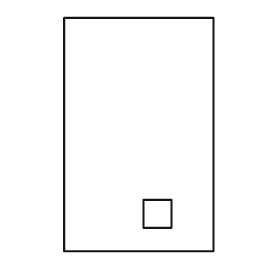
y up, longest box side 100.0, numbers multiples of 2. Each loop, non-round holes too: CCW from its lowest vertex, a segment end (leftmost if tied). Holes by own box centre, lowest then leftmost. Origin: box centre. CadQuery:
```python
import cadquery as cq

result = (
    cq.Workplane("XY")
    .moveTo(-32.0, -50.0)
    .lineTo(32.0, -50.0)
    .lineTo(32.0, 50.0)
    .lineTo(-32.0, 50.0)
    .close()
    .moveTo(2.0, -40.0)
    .lineTo(14.0, -40.0)
    .lineTo(14.0, -28.0)
    .lineTo(2.0, -28.0)
    .close()
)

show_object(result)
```